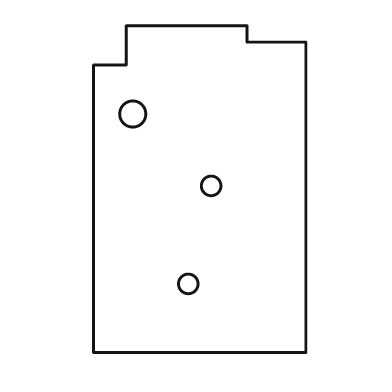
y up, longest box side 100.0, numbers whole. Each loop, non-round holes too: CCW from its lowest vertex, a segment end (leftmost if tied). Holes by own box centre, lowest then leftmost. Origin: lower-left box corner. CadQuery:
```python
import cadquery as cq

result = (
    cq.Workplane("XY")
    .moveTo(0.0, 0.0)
    .lineTo(65.0, 0.0)
    .lineTo(65.0, 95.0)
    .lineTo(47.0, 95.0)
    .lineTo(47.0, 100.0)
    .lineTo(10.0, 100.0)
    .lineTo(10.0, 88.0)
    .lineTo(0.0, 88.0)
    .close()
    .moveTo(29.0, 21.0)
    .circle(3.0)
    .moveTo(36.0, 51.0)
    .circle(3.0)
    .moveTo(12.0, 73.0)
    .circle(4.0)
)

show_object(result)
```